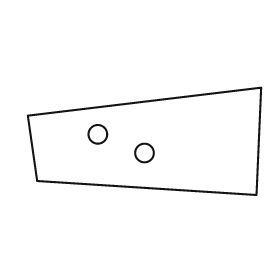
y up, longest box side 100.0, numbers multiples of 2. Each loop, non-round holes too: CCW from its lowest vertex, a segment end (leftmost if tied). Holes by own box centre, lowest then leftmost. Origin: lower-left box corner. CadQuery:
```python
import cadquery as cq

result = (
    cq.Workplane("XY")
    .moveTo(98.0, 0.0)
    .lineTo(100.0, 46.0)
    .lineTo(0.0, 34.0)
    .lineTo(4.0, 6.0)
    .close()
    .moveTo(50.0, 18.0)
    .circle(4.0)
    .moveTo(30.0, 26.0)
    .circle(4.0)
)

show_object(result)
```